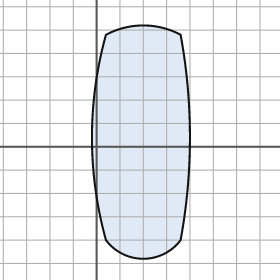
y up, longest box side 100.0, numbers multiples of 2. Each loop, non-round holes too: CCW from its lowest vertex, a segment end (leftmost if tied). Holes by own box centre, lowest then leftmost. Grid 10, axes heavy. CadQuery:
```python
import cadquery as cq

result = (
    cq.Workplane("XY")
    .moveTo(4.0, -40.0)
    .threePointArc((20.0, -48.0), (36.0, -40.0))
    .threePointArc((40.0, 4.0), (36.0, 48.0))
    .threePointArc((20.0, 52.0), (4.0, 48.0))
    .threePointArc((-2.0, 4.0), (4.0, -40.0))
    .close()
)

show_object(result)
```